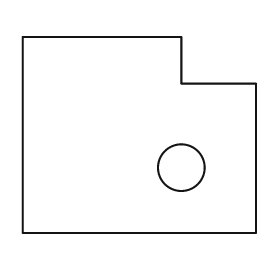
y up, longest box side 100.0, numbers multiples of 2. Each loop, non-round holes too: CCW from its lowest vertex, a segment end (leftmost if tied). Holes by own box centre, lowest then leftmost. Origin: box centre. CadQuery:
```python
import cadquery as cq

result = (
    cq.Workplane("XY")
    .moveTo(-50.0, -42.0)
    .lineTo(50.0, -42.0)
    .lineTo(50.0, 22.0)
    .lineTo(18.0, 22.0)
    .lineTo(18.0, 42.0)
    .lineTo(-50.0, 42.0)
    .close()
    .moveTo(18.0, -14.0)
    .circle(10.0)
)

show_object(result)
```